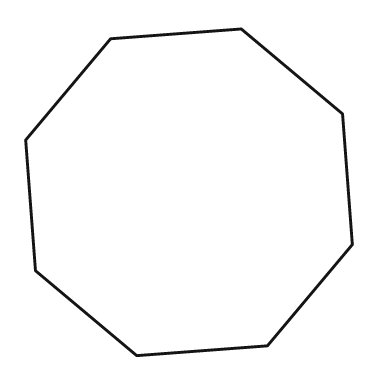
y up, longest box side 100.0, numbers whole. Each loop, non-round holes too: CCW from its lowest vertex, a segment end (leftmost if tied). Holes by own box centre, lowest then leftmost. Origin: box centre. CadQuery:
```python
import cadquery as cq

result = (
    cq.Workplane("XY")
    .moveTo(-16.0, -50.0)
    .lineTo(24.0, -47.0)
    .lineTo(50.0, -16.0)
    .lineTo(47.0, 24.0)
    .lineTo(16.0, 50.0)
    .lineTo(-24.0, 47.0)
    .lineTo(-50.0, 16.0)
    .lineTo(-47.0, -24.0)
    .close()
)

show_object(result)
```